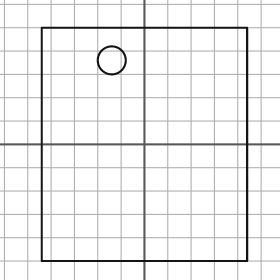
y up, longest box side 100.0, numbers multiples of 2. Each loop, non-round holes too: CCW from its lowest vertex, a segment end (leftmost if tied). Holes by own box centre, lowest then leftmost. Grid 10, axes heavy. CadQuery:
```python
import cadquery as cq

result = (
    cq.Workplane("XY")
    .moveTo(-44.0, -50.0)
    .lineTo(44.0, -50.0)
    .lineTo(44.0, 50.0)
    .lineTo(-44.0, 50.0)
    .close()
    .moveTo(-14.0, 36.0)
    .circle(6.0)
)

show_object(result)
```